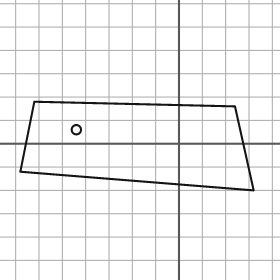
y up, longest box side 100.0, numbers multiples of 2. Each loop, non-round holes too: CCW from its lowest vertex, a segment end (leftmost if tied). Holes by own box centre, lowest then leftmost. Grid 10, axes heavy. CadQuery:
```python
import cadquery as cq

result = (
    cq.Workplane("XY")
    .moveTo(32.0, -20.0)
    .lineTo(24.0, 16.0)
    .lineTo(-62.0, 18.0)
    .lineTo(-68.0, -12.0)
    .close()
    .moveTo(-44.0, 6.0)
    .circle(2.0)
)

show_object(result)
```